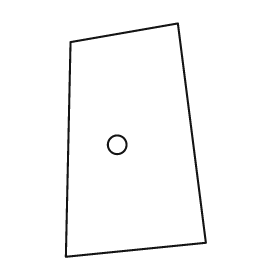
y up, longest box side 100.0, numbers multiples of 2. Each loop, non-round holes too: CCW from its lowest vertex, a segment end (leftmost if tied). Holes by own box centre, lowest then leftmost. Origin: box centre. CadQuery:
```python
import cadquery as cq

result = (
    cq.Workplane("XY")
    .moveTo(-30.0, -50.0)
    .lineTo(30.0, -44.0)
    .lineTo(18.0, 50.0)
    .lineTo(-28.0, 42.0)
    .close()
    .moveTo(-8.0, -2.0)
    .circle(4.0)
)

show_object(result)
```